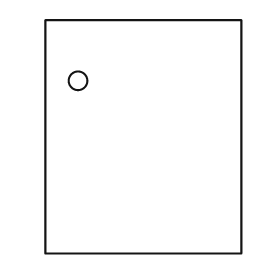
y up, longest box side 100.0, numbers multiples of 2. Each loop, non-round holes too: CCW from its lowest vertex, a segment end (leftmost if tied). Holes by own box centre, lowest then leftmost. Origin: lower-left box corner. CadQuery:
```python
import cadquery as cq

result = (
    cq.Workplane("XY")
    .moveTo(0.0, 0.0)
    .lineTo(84.0, 0.0)
    .lineTo(84.0, 100.0)
    .lineTo(0.0, 100.0)
    .close()
    .moveTo(14.0, 74.0)
    .circle(4.0)
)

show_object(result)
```